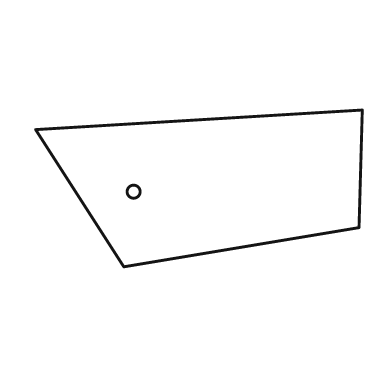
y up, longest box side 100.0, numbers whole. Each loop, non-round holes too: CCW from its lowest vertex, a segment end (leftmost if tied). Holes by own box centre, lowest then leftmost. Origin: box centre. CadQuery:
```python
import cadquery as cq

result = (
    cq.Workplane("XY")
    .moveTo(-23.0, -24.0)
    .lineTo(49.0, -12.0)
    .lineTo(50.0, 24.0)
    .lineTo(-50.0, 18.0)
    .close()
    .moveTo(-20.0, -1.0)
    .circle(2.0)
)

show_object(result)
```